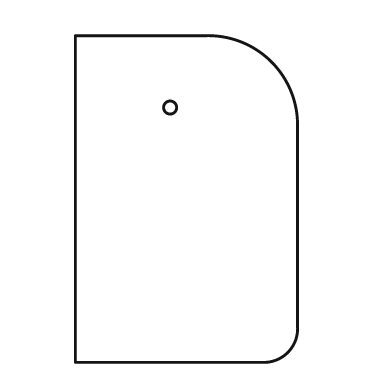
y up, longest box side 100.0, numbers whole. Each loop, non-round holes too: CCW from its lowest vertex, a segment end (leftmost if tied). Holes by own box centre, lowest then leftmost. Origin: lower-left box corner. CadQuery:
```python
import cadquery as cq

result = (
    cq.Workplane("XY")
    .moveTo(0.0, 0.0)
    .lineTo(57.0, 0.0)
    .threePointArc((65.0, 3.0), (68.0, 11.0))
    .lineTo(68.0, 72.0)
    .threePointArc((60.0, 92.0), (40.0, 100.0))
    .lineTo(0.0, 100.0)
    .close()
    .moveTo(29.0, 78.0)
    .circle(2.0)
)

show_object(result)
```